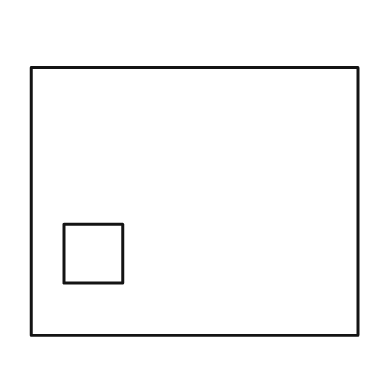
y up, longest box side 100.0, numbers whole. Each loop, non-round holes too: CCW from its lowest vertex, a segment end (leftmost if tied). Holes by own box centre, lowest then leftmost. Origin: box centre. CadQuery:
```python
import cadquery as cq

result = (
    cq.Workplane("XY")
    .moveTo(-50.0, -41.0)
    .lineTo(50.0, -41.0)
    .lineTo(50.0, 41.0)
    .lineTo(-50.0, 41.0)
    .close()
    .moveTo(-40.0, -25.0)
    .lineTo(-22.0, -25.0)
    .lineTo(-22.0, -7.0)
    .lineTo(-40.0, -7.0)
    .close()
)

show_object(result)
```